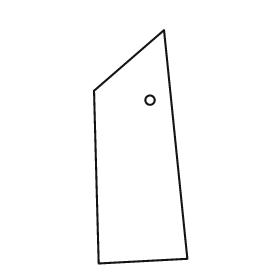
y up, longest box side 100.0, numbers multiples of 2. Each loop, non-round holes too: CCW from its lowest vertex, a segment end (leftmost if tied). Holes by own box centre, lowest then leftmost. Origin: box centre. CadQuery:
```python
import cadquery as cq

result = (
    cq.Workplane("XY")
    .moveTo(-18.0, -50.0)
    .lineTo(20.0, -48.0)
    .lineTo(10.0, 50.0)
    .lineTo(-20.0, 24.0)
    .close()
    .moveTo(4.0, 20.0)
    .circle(2.0)
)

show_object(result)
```